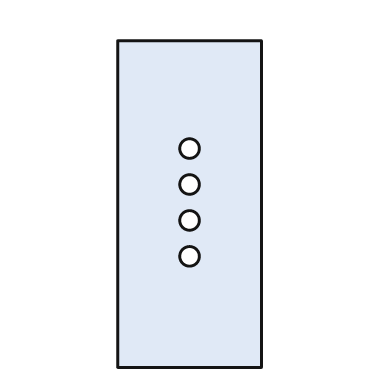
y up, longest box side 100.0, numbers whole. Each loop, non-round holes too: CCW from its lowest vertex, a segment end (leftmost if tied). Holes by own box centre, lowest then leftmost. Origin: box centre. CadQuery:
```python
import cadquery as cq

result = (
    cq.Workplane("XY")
    .moveTo(-22.0, -50.0)
    .lineTo(22.0, -50.0)
    .lineTo(22.0, 50.0)
    .lineTo(-22.0, 50.0)
    .close()
    .moveTo(0.0, -16.0)
    .circle(3.0)
    .moveTo(0.0, -5.0)
    .circle(3.0)
    .moveTo(0.0, 6.0)
    .circle(3.0)
    .moveTo(0.0, 17.0)
    .circle(3.0)
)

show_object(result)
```